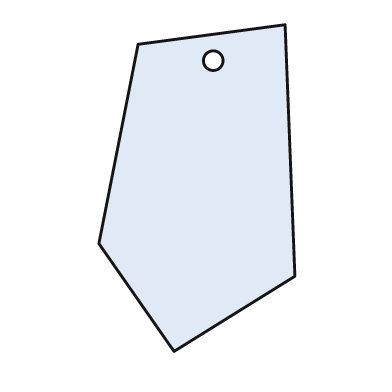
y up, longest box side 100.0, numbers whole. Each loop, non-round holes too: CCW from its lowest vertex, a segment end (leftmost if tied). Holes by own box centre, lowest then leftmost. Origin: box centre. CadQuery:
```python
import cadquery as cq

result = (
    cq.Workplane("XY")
    .moveTo(-7.0, -50.0)
    .lineTo(30.0, -27.0)
    .lineTo(27.0, 50.0)
    .lineTo(-18.0, 44.0)
    .lineTo(-30.0, -17.0)
    .close()
    .moveTo(5.0, 39.0)
    .circle(3.0)
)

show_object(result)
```